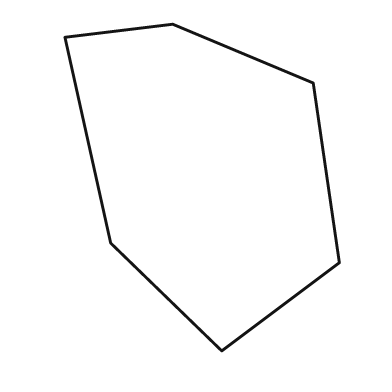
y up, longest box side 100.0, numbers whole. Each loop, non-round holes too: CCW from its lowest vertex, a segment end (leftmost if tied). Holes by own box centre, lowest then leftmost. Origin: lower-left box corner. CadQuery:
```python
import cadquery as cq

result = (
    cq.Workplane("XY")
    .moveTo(48.0, 0.0)
    .lineTo(84.0, 27.0)
    .lineTo(76.0, 82.0)
    .lineTo(33.0, 100.0)
    .lineTo(0.0, 96.0)
    .lineTo(14.0, 33.0)
    .close()
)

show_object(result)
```